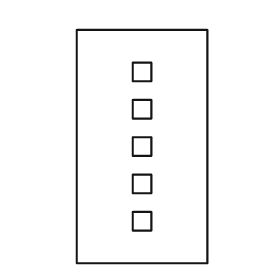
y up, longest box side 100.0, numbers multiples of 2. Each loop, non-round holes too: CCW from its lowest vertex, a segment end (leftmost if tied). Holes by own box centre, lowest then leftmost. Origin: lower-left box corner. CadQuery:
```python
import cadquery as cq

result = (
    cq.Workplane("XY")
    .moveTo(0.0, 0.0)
    .lineTo(56.0, 0.0)
    .lineTo(56.0, 100.0)
    .lineTo(0.0, 100.0)
    .close()
    .moveTo(24.0, 14.0)
    .lineTo(32.0, 14.0)
    .lineTo(32.0, 22.0)
    .lineTo(24.0, 22.0)
    .close()
    .moveTo(24.0, 30.0)
    .lineTo(32.0, 30.0)
    .lineTo(32.0, 38.0)
    .lineTo(24.0, 38.0)
    .close()
    .moveTo(24.0, 46.0)
    .lineTo(32.0, 46.0)
    .lineTo(32.0, 54.0)
    .lineTo(24.0, 54.0)
    .close()
    .moveTo(24.0, 62.0)
    .lineTo(32.0, 62.0)
    .lineTo(32.0, 70.0)
    .lineTo(24.0, 70.0)
    .close()
    .moveTo(24.0, 78.0)
    .lineTo(32.0, 78.0)
    .lineTo(32.0, 86.0)
    .lineTo(24.0, 86.0)
    .close()
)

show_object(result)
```